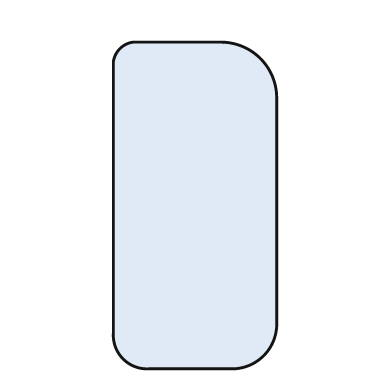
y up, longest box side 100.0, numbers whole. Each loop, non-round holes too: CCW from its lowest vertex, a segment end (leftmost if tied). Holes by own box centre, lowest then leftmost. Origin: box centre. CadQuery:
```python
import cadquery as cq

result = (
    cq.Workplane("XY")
    .moveTo(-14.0, -50.0)
    .lineTo(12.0, -50.0)
    .threePointArc((21.0, -46.0), (25.0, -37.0))
    .lineTo(25.0, 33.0)
    .threePointArc((20.0, 45.0), (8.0, 50.0))
    .lineTo(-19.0, 50.0)
    .threePointArc((-23.0, 48.0), (-25.0, 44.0))
    .lineTo(-25.0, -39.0)
    .threePointArc((-22.0, -47.0), (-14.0, -50.0))
    .close()
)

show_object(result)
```